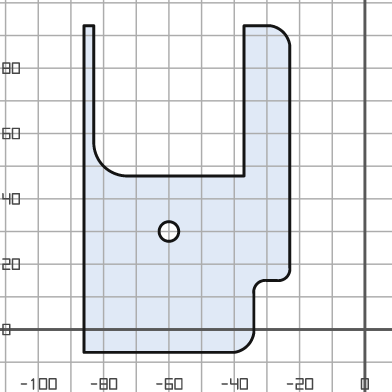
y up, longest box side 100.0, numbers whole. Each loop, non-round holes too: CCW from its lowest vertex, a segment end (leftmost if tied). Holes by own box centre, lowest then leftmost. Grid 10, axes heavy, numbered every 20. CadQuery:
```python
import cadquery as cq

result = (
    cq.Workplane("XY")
    .moveTo(-86.0, -7.0)
    .lineTo(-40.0, -7.0)
    .threePointArc((-36.0, -5.0), (-34.0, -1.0))
    .lineTo(-34.0, 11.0)
    .threePointArc((-33.0, 14.0), (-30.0, 15.0))
    .lineTo(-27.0, 15.0)
    .threePointArc((-24.0, 16.0), (-23.0, 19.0))
    .lineTo(-23.0, 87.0)
    .threePointArc((-25.0, 91.0), (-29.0, 93.0))
    .lineTo(-37.0, 93.0)
    .lineTo(-37.0, 47.0)
    .lineTo(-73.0, 47.0)
    .threePointArc((-80.0, 50.0), (-83.0, 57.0))
    .lineTo(-83.0, 93.0)
    .lineTo(-86.0, 93.0)
    .close()
    .moveTo(-60.0, 30.0)
    .circle(3.0)
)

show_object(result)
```